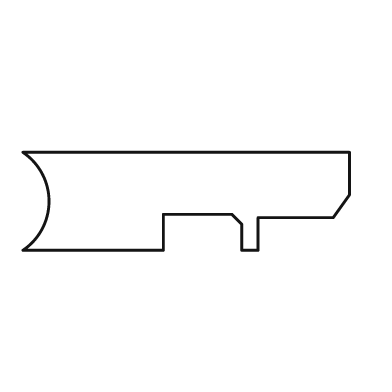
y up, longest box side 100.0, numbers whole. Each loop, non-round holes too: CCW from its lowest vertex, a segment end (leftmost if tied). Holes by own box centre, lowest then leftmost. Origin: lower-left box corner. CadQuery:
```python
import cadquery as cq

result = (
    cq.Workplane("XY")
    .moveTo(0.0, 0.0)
    .lineTo(43.0, 0.0)
    .lineTo(43.0, 11.0)
    .lineTo(64.0, 11.0)
    .lineTo(67.0, 8.0)
    .lineTo(67.0, 0.0)
    .lineTo(72.0, 0.0)
    .lineTo(72.0, 10.0)
    .lineTo(95.0, 10.0)
    .lineTo(100.0, 17.0)
    .lineTo(100.0, 30.0)
    .lineTo(0.0, 30.0)
    .threePointArc((8.0, 15.0), (0.0, 0.0))
    .close()
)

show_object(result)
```